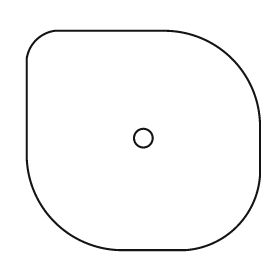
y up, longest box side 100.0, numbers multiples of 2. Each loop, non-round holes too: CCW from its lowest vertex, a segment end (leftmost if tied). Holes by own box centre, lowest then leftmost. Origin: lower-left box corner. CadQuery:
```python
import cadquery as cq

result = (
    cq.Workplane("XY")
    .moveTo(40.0, 0.0)
    .lineTo(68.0, 0.0)
    .threePointArc((90.0, 10.0), (100.0, 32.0))
    .lineTo(100.0, 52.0)
    .threePointArc((88.0, 82.0), (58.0, 94.0))
    .lineTo(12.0, 94.0)
    .threePointArc((4.0, 90.0), (0.0, 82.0))
    .lineTo(0.0, 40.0)
    .threePointArc((12.0, 12.0), (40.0, 0.0))
    .close()
    .moveTo(50.0, 48.0)
    .circle(4.0)
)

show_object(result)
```